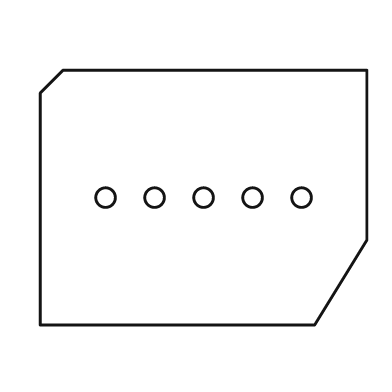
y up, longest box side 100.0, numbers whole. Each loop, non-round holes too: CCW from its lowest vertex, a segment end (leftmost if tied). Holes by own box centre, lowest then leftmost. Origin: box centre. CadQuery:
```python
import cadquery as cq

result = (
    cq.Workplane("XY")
    .moveTo(-50.0, -39.0)
    .lineTo(34.0, -39.0)
    .lineTo(50.0, -13.0)
    .lineTo(50.0, 39.0)
    .lineTo(-43.0, 39.0)
    .lineTo(-50.0, 32.0)
    .close()
    .moveTo(-30.0, 0.0)
    .circle(3.0)
    .moveTo(-15.0, 0.0)
    .circle(3.0)
    .moveTo(0.0, 0.0)
    .circle(3.0)
    .moveTo(15.0, 0.0)
    .circle(3.0)
    .moveTo(30.0, 0.0)
    .circle(3.0)
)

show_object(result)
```